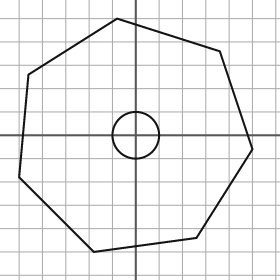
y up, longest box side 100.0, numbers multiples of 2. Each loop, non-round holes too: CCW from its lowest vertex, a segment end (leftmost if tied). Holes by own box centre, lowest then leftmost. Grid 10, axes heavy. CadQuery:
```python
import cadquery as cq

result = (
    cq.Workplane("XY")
    .moveTo(-18.0, -50.0)
    .lineTo(26.0, -44.0)
    .lineTo(50.0, -6.0)
    .lineTo(36.0, 36.0)
    .lineTo(-8.0, 50.0)
    .lineTo(-46.0, 26.0)
    .lineTo(-50.0, -18.0)
    .close()
    .moveTo(0.0, 0.0)
    .circle(10.0)
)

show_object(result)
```